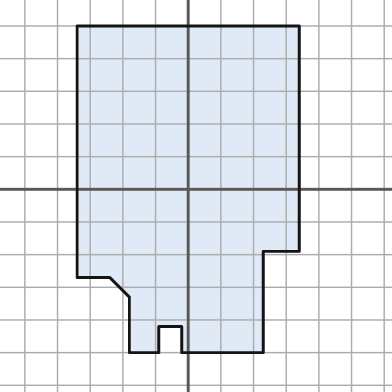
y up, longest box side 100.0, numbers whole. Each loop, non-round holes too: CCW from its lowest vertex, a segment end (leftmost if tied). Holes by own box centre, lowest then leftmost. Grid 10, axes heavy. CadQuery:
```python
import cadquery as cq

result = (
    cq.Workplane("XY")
    .moveTo(-18.0, -50.0)
    .lineTo(-9.0, -50.0)
    .lineTo(-9.0, -42.0)
    .lineTo(-2.0, -42.0)
    .lineTo(-2.0, -50.0)
    .lineTo(23.0, -50.0)
    .lineTo(23.0, -19.0)
    .lineTo(34.0, -19.0)
    .lineTo(34.0, 50.0)
    .lineTo(-34.0, 50.0)
    .lineTo(-34.0, -27.0)
    .lineTo(-24.0, -27.0)
    .lineTo(-18.0, -33.0)
    .close()
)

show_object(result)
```